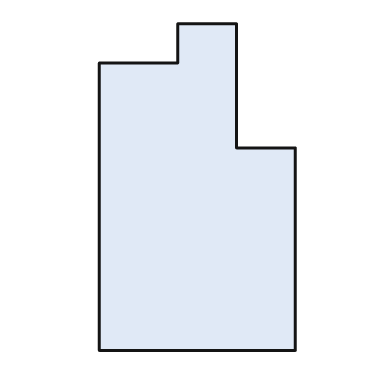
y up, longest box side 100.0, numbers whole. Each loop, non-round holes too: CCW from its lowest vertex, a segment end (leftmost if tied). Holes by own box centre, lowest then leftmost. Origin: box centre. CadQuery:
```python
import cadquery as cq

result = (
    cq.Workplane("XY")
    .moveTo(-30.0, -50.0)
    .lineTo(30.0, -50.0)
    .lineTo(30.0, 12.0)
    .lineTo(12.0, 12.0)
    .lineTo(12.0, 50.0)
    .lineTo(-6.0, 50.0)
    .lineTo(-6.0, 38.0)
    .lineTo(-30.0, 38.0)
    .close()
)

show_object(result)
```